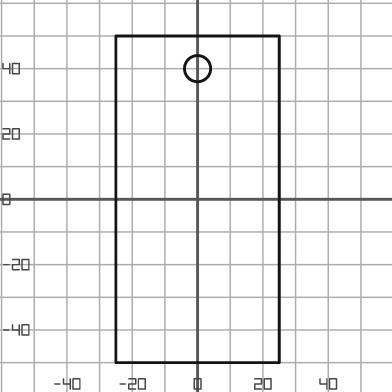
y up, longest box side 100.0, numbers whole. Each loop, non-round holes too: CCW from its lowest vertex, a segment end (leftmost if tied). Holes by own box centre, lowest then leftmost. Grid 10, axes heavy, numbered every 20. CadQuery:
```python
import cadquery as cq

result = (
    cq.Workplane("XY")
    .moveTo(-25.0, -50.0)
    .lineTo(25.0, -50.0)
    .lineTo(25.0, 50.0)
    .lineTo(-25.0, 50.0)
    .close()
    .moveTo(0.0, 40.0)
    .circle(4.0)
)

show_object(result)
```